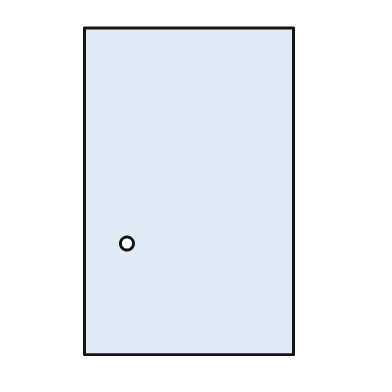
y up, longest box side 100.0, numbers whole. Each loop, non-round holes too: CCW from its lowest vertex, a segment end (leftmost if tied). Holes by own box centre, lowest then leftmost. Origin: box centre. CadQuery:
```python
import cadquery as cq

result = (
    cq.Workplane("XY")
    .moveTo(-32.0, -50.0)
    .lineTo(32.0, -50.0)
    .lineTo(32.0, 50.0)
    .lineTo(-32.0, 50.0)
    .close()
    .moveTo(-19.0, -16.0)
    .circle(2.0)
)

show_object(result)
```